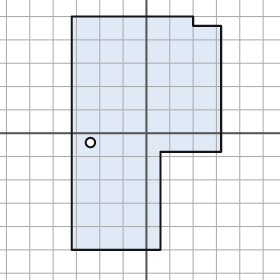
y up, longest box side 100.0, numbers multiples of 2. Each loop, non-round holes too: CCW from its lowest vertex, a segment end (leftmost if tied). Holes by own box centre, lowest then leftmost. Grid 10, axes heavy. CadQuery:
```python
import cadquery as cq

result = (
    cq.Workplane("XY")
    .moveTo(-32.0, -50.0)
    .lineTo(6.0, -50.0)
    .lineTo(6.0, -8.0)
    .lineTo(32.0, -8.0)
    .lineTo(32.0, 46.0)
    .lineTo(20.0, 46.0)
    .lineTo(20.0, 50.0)
    .lineTo(-32.0, 50.0)
    .close()
    .moveTo(-24.0, -4.0)
    .circle(2.0)
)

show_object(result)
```